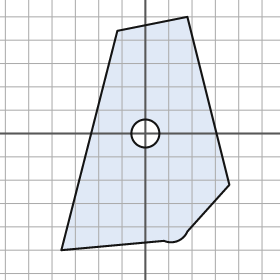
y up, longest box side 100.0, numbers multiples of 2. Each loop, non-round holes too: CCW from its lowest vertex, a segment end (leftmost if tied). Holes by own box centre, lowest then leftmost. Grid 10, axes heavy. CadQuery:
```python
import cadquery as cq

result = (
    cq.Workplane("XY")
    .moveTo(-36.0, -50.0)
    .lineTo(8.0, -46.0)
    .threePointArc((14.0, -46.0), (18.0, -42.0))
    .lineTo(36.0, -22.0)
    .lineTo(18.0, 50.0)
    .lineTo(-12.0, 44.0)
    .close()
    .moveTo(0.0, 0.0)
    .circle(6.0)
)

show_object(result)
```